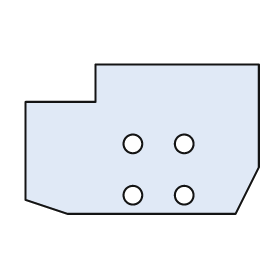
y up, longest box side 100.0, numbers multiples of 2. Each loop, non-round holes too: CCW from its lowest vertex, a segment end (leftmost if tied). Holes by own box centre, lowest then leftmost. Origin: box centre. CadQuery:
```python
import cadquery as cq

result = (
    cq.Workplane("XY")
    .moveTo(-32.0, -32.0)
    .lineTo(40.0, -32.0)
    .lineTo(50.0, -12.0)
    .lineTo(50.0, 32.0)
    .lineTo(-20.0, 32.0)
    .lineTo(-20.0, 16.0)
    .lineTo(-50.0, 16.0)
    .lineTo(-50.0, -26.0)
    .close()
    .moveTo(-4.0, -24.0)
    .circle(4.0)
    .moveTo(18.0, -24.0)
    .circle(4.0)
    .moveTo(-4.0, -2.0)
    .circle(4.0)
    .moveTo(18.0, -2.0)
    .circle(4.0)
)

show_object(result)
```